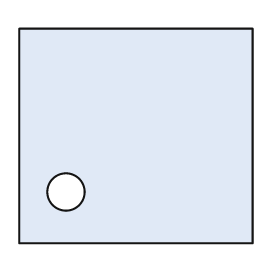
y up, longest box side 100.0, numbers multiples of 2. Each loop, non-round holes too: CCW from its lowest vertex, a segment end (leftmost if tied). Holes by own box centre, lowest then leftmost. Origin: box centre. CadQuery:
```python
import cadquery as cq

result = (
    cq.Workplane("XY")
    .moveTo(-50.0, -46.0)
    .lineTo(50.0, -46.0)
    .lineTo(50.0, 46.0)
    .lineTo(-50.0, 46.0)
    .close()
    .moveTo(-30.0, -24.0)
    .circle(8.0)
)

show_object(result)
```